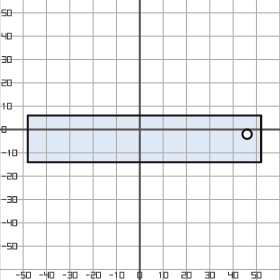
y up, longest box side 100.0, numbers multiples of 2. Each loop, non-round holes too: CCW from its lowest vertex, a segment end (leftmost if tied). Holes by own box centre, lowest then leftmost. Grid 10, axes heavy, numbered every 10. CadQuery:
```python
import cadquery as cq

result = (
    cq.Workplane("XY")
    .moveTo(-48.0, -14.0)
    .lineTo(52.0, -14.0)
    .lineTo(52.0, 6.0)
    .lineTo(-48.0, 6.0)
    .close()
    .moveTo(46.0, -2.0)
    .circle(2.0)
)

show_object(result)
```